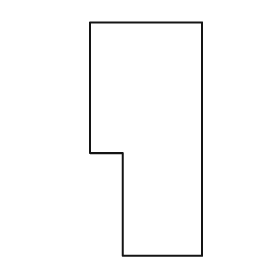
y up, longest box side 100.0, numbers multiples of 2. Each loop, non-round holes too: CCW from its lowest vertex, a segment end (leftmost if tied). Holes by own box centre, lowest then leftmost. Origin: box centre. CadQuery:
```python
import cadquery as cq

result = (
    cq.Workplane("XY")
    .moveTo(-10.0, -50.0)
    .lineTo(24.0, -50.0)
    .lineTo(24.0, 50.0)
    .lineTo(-24.0, 50.0)
    .lineTo(-24.0, -6.0)
    .lineTo(-10.0, -6.0)
    .close()
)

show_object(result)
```